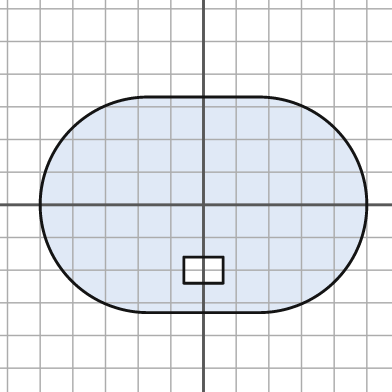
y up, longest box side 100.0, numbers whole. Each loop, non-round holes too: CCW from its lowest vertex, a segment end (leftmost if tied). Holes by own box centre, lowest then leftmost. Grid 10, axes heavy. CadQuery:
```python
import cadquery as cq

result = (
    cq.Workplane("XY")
    .moveTo(-17.0, -33.0)
    .lineTo(17.0, -33.0)
    .threePointArc((50.0, 0.0), (17.0, 33.0))
    .lineTo(-17.0, 33.0)
    .threePointArc((-50.0, 0.0), (-17.0, -33.0))
    .close()
    .moveTo(-6.0, -24.0)
    .lineTo(6.0, -24.0)
    .lineTo(6.0, -16.0)
    .lineTo(-6.0, -16.0)
    .close()
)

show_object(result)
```